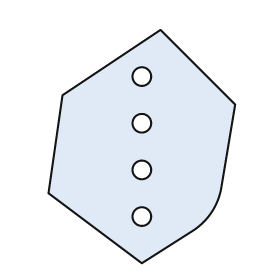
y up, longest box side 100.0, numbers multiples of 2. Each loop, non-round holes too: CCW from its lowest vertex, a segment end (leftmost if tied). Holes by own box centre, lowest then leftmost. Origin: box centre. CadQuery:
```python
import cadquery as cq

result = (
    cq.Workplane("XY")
    .moveTo(0.0, -50.0)
    .lineTo(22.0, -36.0)
    .threePointArc((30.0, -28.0), (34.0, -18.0))
    .lineTo(40.0, 18.0)
    .lineTo(8.0, 50.0)
    .lineTo(-34.0, 22.0)
    .lineTo(-40.0, -20.0)
    .close()
    .moveTo(0.0, -30.0)
    .circle(4.0)
    .moveTo(0.0, -10.0)
    .circle(4.0)
    .moveTo(0.0, 10.0)
    .circle(4.0)
    .moveTo(0.0, 30.0)
    .circle(4.0)
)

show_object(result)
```